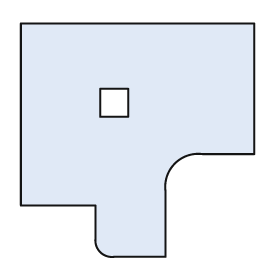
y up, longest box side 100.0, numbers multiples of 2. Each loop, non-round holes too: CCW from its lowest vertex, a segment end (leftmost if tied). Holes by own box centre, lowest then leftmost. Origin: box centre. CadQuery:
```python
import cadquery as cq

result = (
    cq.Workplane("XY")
    .moveTo(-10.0, -50.0)
    .lineTo(12.0, -50.0)
    .lineTo(12.0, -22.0)
    .threePointArc((16.0, -10.0), (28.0, -6.0))
    .lineTo(50.0, -6.0)
    .lineTo(50.0, 50.0)
    .lineTo(-50.0, 50.0)
    .lineTo(-50.0, -28.0)
    .lineTo(-18.0, -28.0)
    .lineTo(-18.0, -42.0)
    .threePointArc((-16.0, -48.0), (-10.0, -50.0))
    .close()
    .moveTo(-16.0, 10.0)
    .lineTo(-4.0, 10.0)
    .lineTo(-4.0, 22.0)
    .lineTo(-16.0, 22.0)
    .close()
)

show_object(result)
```